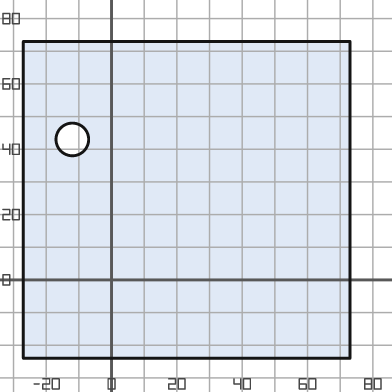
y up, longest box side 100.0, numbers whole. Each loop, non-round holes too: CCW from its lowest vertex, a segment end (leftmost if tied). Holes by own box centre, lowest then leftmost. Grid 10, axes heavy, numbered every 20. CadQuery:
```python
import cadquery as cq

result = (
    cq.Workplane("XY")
    .moveTo(-27.0, -24.0)
    .lineTo(73.0, -24.0)
    .lineTo(73.0, 73.0)
    .lineTo(-27.0, 73.0)
    .close()
    .moveTo(-12.0, 43.0)
    .circle(5.0)
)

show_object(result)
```